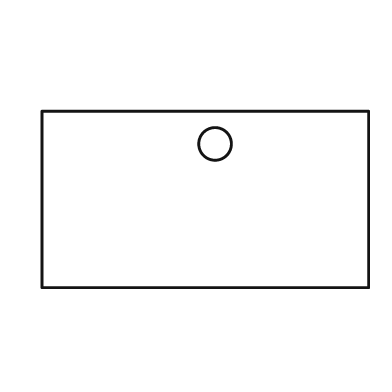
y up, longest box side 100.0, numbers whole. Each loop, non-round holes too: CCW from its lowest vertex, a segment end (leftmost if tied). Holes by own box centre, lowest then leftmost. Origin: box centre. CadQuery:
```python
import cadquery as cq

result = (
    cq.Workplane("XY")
    .moveTo(-50.0, -27.0)
    .lineTo(50.0, -27.0)
    .lineTo(50.0, 27.0)
    .lineTo(-50.0, 27.0)
    .close()
    .moveTo(3.0, 17.0)
    .circle(5.0)
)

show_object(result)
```